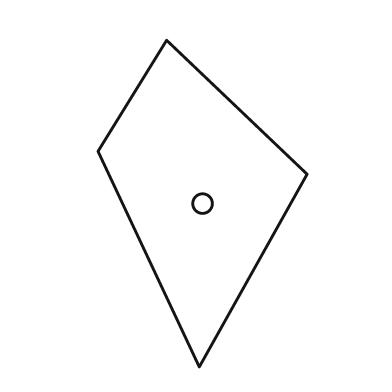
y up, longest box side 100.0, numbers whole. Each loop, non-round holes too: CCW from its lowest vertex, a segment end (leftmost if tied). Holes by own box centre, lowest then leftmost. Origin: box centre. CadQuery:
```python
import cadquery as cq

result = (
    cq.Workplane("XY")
    .moveTo(-1.0, -50.0)
    .lineTo(32.0, 9.0)
    .lineTo(-11.0, 50.0)
    .lineTo(-32.0, 16.0)
    .close()
    .moveTo(0.0, 0.0)
    .circle(3.0)
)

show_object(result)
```